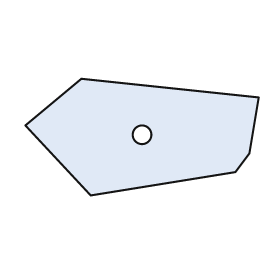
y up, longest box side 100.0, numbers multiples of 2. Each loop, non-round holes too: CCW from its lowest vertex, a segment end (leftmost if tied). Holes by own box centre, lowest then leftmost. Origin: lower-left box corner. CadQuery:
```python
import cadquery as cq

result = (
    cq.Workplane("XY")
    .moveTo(28.0, 0.0)
    .lineTo(90.0, 10.0)
    .lineTo(96.0, 18.0)
    .lineTo(100.0, 42.0)
    .lineTo(24.0, 50.0)
    .lineTo(0.0, 30.0)
    .close()
    .moveTo(50.0, 26.0)
    .circle(4.0)
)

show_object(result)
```